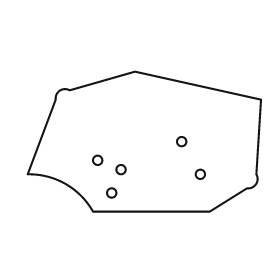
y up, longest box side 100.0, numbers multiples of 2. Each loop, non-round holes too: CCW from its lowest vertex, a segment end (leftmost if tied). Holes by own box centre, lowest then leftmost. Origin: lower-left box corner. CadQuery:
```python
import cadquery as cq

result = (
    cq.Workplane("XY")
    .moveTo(28.0, 0.0)
    .lineTo(78.0, 0.0)
    .lineTo(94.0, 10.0)
    .threePointArc((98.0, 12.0), (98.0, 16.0))
    .lineTo(100.0, 48.0)
    .lineTo(46.0, 60.0)
    .lineTo(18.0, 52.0)
    .threePointArc((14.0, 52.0), (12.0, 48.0))
    .lineTo(0.0, 16.0)
    .threePointArc((16.0, 12.0), (28.0, 0.0))
    .close()
    .moveTo(36.0, 8.0)
    .circle(2.0)
    .moveTo(74.0, 16.0)
    .circle(2.0)
    .moveTo(40.0, 18.0)
    .circle(2.0)
    .moveTo(30.0, 22.0)
    .circle(2.0)
    .moveTo(66.0, 30.0)
    .circle(2.0)
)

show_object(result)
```